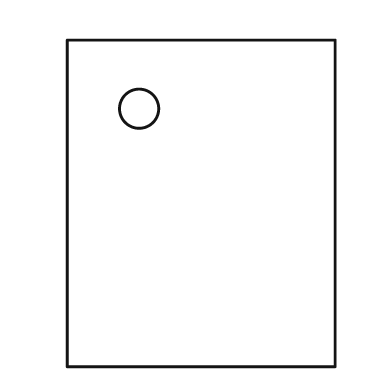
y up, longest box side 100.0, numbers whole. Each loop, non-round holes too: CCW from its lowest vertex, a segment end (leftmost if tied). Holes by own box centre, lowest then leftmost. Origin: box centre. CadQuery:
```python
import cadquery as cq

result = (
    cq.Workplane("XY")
    .moveTo(-41.0, -50.0)
    .lineTo(41.0, -50.0)
    .lineTo(41.0, 50.0)
    .lineTo(-41.0, 50.0)
    .close()
    .moveTo(-19.0, 29.0)
    .circle(6.0)
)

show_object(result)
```